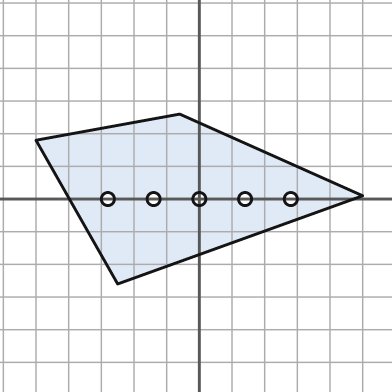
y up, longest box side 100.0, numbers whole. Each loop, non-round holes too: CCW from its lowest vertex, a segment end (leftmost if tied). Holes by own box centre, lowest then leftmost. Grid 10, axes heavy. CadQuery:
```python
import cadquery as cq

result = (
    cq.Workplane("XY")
    .moveTo(-25.0, -26.0)
    .lineTo(50.0, 1.0)
    .lineTo(-6.0, 26.0)
    .lineTo(-50.0, 18.0)
    .close()
    .moveTo(-28.0, 0.0)
    .circle(2.0)
    .moveTo(-14.0, 0.0)
    .circle(2.0)
    .moveTo(0.0, 0.0)
    .circle(2.0)
    .moveTo(14.0, 0.0)
    .circle(2.0)
    .moveTo(28.0, 0.0)
    .circle(2.0)
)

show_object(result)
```